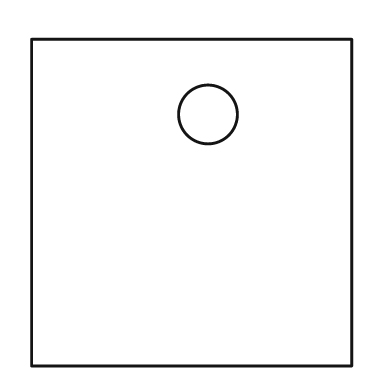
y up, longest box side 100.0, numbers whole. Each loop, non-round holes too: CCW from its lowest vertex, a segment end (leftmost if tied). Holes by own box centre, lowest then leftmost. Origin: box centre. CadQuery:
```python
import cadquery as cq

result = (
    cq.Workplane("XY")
    .moveTo(-49.0, -50.0)
    .lineTo(49.0, -50.0)
    .lineTo(49.0, 50.0)
    .lineTo(-49.0, 50.0)
    .close()
    .moveTo(5.0, 27.0)
    .circle(9.0)
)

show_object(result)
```